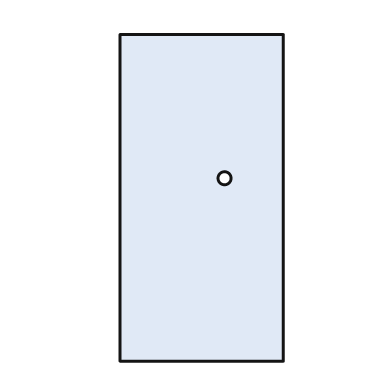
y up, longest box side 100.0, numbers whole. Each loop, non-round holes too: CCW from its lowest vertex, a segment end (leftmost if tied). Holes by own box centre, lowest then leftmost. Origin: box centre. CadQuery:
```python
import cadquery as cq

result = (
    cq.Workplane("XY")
    .moveTo(-25.0, -50.0)
    .lineTo(25.0, -50.0)
    .lineTo(25.0, 50.0)
    .lineTo(-25.0, 50.0)
    .close()
    .moveTo(7.0, 6.0)
    .circle(2.0)
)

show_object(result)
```